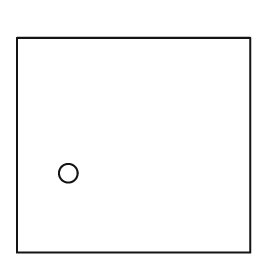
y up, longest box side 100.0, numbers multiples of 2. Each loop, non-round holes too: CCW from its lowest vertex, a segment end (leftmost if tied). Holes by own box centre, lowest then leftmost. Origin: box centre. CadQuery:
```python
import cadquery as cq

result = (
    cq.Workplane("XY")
    .moveTo(-50.0, -46.0)
    .lineTo(50.0, -46.0)
    .lineTo(50.0, 46.0)
    .lineTo(-50.0, 46.0)
    .close()
    .moveTo(-28.0, -12.0)
    .circle(4.0)
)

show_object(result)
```